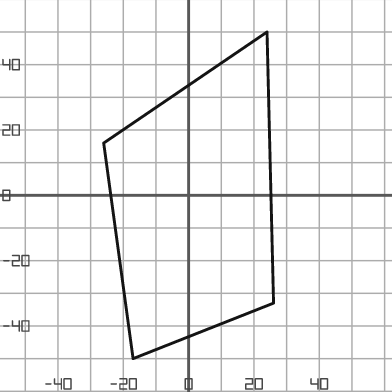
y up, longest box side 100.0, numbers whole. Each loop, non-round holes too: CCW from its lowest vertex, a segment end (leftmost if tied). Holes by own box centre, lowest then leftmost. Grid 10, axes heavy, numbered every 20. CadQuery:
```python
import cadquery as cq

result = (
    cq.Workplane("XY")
    .moveTo(-17.0, -50.0)
    .lineTo(26.0, -33.0)
    .lineTo(24.0, 50.0)
    .lineTo(-26.0, 16.0)
    .close()
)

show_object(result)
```